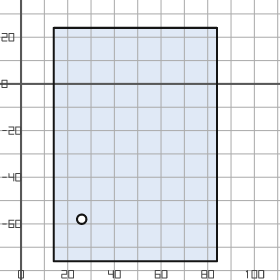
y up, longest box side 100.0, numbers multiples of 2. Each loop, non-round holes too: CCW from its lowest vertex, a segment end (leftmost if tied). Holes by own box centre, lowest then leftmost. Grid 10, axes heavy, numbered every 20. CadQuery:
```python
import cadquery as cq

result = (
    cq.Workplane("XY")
    .moveTo(14.0, -76.0)
    .lineTo(84.0, -76.0)
    .lineTo(84.0, 24.0)
    .lineTo(14.0, 24.0)
    .close()
    .moveTo(26.0, -58.0)
    .circle(2.0)
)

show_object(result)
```